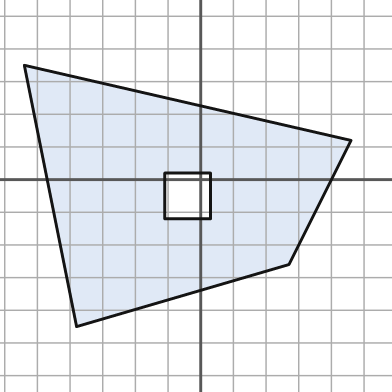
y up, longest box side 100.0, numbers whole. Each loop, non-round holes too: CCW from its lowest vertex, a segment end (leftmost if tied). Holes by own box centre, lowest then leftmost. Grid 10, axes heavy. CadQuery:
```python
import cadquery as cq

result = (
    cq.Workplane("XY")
    .moveTo(-38.0, -45.0)
    .lineTo(27.0, -26.0)
    .lineTo(46.0, 12.0)
    .lineTo(-54.0, 35.0)
    .close()
    .moveTo(-11.0, -12.0)
    .lineTo(3.0, -12.0)
    .lineTo(3.0, 2.0)
    .lineTo(-11.0, 2.0)
    .close()
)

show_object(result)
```